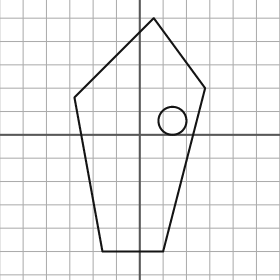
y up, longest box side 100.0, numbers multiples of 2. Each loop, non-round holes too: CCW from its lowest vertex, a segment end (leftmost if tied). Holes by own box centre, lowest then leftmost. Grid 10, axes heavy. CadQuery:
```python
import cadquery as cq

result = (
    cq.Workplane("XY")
    .moveTo(-16.0, -50.0)
    .lineTo(10.0, -50.0)
    .lineTo(28.0, 20.0)
    .lineTo(6.0, 50.0)
    .lineTo(-28.0, 16.0)
    .close()
    .moveTo(14.0, 6.0)
    .circle(6.0)
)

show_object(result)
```